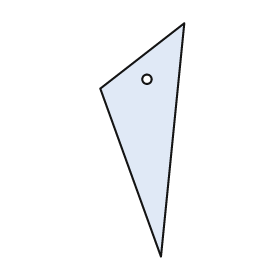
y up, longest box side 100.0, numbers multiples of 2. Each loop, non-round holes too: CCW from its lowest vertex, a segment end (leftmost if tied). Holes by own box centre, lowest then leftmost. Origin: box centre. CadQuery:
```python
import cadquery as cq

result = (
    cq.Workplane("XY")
    .moveTo(8.0, -50.0)
    .lineTo(18.0, 50.0)
    .lineTo(-18.0, 22.0)
    .close()
    .moveTo(2.0, 26.0)
    .circle(2.0)
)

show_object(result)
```